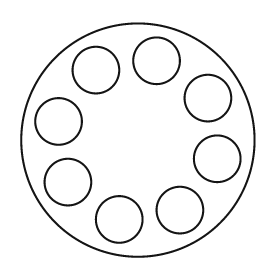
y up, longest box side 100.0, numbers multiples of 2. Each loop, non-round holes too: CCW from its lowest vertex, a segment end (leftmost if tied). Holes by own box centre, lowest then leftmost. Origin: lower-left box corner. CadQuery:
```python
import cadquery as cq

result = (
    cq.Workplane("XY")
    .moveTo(50.0, 50.0)
    .circle(50.0)
    .moveTo(42.0, 16.0)
    .circle(10.0)
    .moveTo(68.0, 20.0)
    .circle(10.0)
    .moveTo(20.0, 32.0)
    .circle(10.0)
    .moveTo(84.0, 42.0)
    .circle(10.0)
    .moveTo(16.0, 58.0)
    .circle(10.0)
    .moveTo(80.0, 68.0)
    .circle(10.0)
    .moveTo(32.0, 80.0)
    .circle(10.0)
    .moveTo(58.0, 84.0)
    .circle(10.0)
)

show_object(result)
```